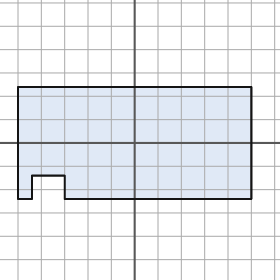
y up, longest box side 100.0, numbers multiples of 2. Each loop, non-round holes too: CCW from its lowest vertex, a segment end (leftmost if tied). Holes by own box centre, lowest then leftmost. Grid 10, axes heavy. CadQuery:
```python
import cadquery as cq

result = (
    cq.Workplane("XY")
    .moveTo(-50.0, -24.0)
    .lineTo(-44.0, -24.0)
    .lineTo(-44.0, -14.0)
    .lineTo(-30.0, -14.0)
    .lineTo(-30.0, -24.0)
    .lineTo(50.0, -24.0)
    .lineTo(50.0, 24.0)
    .lineTo(-50.0, 24.0)
    .close()
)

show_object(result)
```